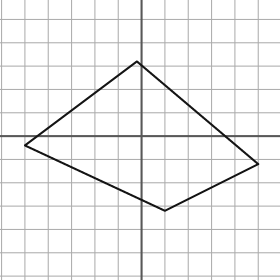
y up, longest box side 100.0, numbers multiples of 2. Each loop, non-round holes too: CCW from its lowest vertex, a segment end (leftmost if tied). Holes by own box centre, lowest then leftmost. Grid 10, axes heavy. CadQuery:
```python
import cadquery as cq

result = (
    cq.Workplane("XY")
    .moveTo(10.0, -32.0)
    .lineTo(50.0, -12.0)
    .lineTo(-2.0, 32.0)
    .lineTo(-50.0, -4.0)
    .close()
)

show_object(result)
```